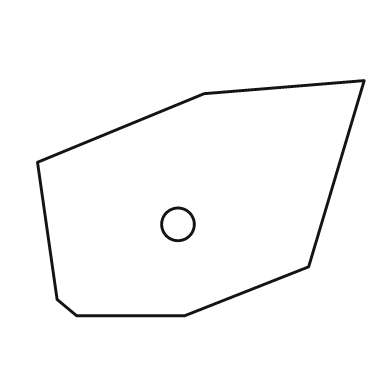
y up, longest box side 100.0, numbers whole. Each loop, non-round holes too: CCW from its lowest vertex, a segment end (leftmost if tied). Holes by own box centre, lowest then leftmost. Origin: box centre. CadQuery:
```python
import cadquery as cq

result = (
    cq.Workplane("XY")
    .moveTo(-38.0, -36.0)
    .lineTo(-5.0, -36.0)
    .lineTo(33.0, -21.0)
    .lineTo(50.0, 36.0)
    .lineTo(1.0, 32.0)
    .lineTo(-50.0, 11.0)
    .lineTo(-44.0, -31.0)
    .close()
    .moveTo(-7.0, -8.0)
    .circle(5.0)
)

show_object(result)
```